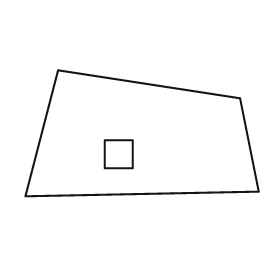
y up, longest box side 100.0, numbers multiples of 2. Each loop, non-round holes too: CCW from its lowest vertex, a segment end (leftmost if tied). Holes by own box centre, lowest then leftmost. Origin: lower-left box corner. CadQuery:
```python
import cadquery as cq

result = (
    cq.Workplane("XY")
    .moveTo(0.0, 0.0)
    .lineTo(100.0, 2.0)
    .lineTo(92.0, 42.0)
    .lineTo(14.0, 54.0)
    .close()
    .moveTo(34.0, 12.0)
    .lineTo(46.0, 12.0)
    .lineTo(46.0, 24.0)
    .lineTo(34.0, 24.0)
    .close()
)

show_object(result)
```